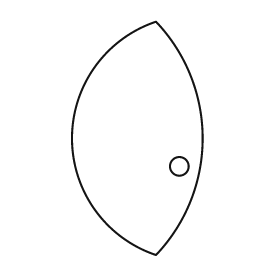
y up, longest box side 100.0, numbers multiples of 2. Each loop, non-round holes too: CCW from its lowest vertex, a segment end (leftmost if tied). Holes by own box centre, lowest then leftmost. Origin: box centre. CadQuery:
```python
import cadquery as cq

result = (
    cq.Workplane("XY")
    .moveTo(8.0, -50.0)
    .threePointArc((28.0, 0.0), (8.0, 50.0))
    .threePointArc((-28.0, 0.0), (8.0, -50.0))
    .close()
    .moveTo(18.0, -12.0)
    .circle(4.0)
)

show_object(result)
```